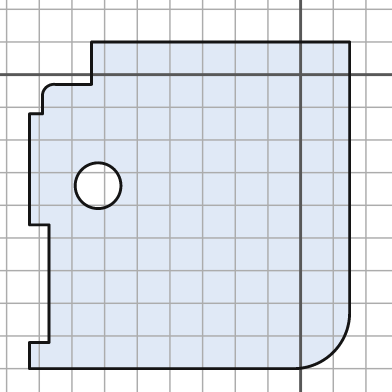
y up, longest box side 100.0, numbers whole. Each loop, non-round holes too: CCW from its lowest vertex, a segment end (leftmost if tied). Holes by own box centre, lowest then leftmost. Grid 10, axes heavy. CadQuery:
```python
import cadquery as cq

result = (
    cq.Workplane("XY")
    .moveTo(-83.0, -90.0)
    .lineTo(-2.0, -90.0)
    .threePointArc((10.0, -85.0), (15.0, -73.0))
    .lineTo(15.0, 10.0)
    .lineTo(-64.0, 10.0)
    .lineTo(-64.0, -3.0)
    .lineTo(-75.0, -3.0)
    .threePointArc((-78.0, -4.0), (-79.0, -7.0))
    .lineTo(-79.0, -12.0)
    .lineTo(-83.0, -12.0)
    .lineTo(-83.0, -46.0)
    .lineTo(-77.0, -46.0)
    .lineTo(-77.0, -82.0)
    .lineTo(-83.0, -82.0)
    .close()
    .moveTo(-62.0, -34.0)
    .circle(7.0)
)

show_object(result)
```